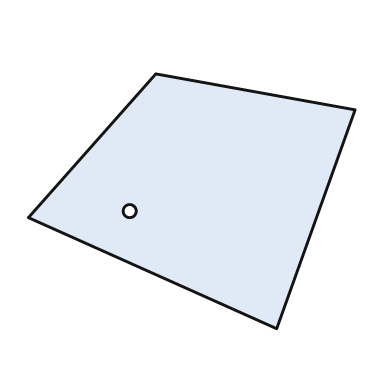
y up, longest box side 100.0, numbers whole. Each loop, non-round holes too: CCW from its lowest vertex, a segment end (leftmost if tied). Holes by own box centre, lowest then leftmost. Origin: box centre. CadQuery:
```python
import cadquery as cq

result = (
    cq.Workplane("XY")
    .moveTo(26.0, -39.0)
    .lineTo(50.0, 28.0)
    .lineTo(-11.0, 39.0)
    .lineTo(-50.0, -5.0)
    .close()
    .moveTo(-19.0, -3.0)
    .circle(2.0)
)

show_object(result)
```